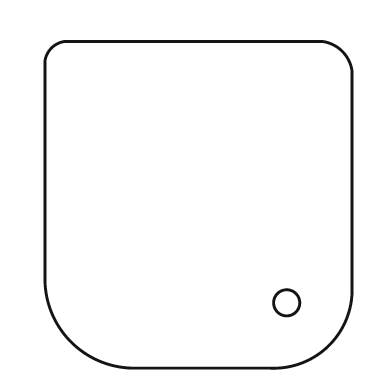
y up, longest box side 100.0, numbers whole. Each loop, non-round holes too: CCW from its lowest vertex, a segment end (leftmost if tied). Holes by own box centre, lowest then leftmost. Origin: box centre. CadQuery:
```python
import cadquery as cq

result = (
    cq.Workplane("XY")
    .moveTo(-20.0, -50.0)
    .lineTo(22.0, -50.0)
    .threePointArc((40.0, -43.0), (47.0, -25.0))
    .lineTo(47.0, 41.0)
    .threePointArc((44.0, 47.0), (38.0, 50.0))
    .lineTo(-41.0, 50.0)
    .threePointArc((-45.0, 48.0), (-47.0, 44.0))
    .lineTo(-47.0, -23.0)
    .threePointArc((-39.0, -42.0), (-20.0, -50.0))
    .close()
    .moveTo(27.0, -30.0)
    .circle(4.0)
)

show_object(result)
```